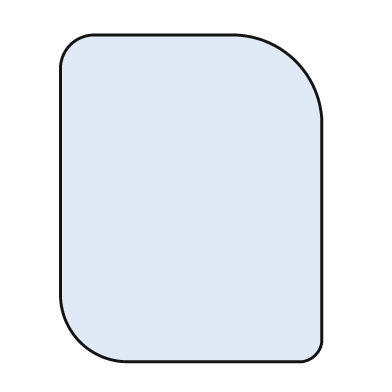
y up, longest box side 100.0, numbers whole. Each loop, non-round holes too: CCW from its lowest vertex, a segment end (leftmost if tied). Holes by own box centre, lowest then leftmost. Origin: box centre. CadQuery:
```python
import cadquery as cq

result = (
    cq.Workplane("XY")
    .moveTo(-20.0, -50.0)
    .lineTo(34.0, -50.0)
    .threePointArc((38.0, -48.0), (40.0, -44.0))
    .lineTo(40.0, 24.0)
    .threePointArc((32.0, 42.0), (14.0, 50.0))
    .lineTo(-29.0, 50.0)
    .threePointArc((-37.0, 47.0), (-40.0, 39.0))
    .lineTo(-40.0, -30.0)
    .threePointArc((-34.0, -44.0), (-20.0, -50.0))
    .close()
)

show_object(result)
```